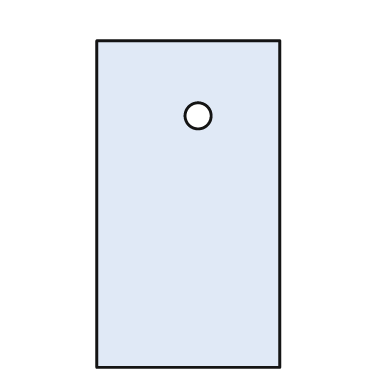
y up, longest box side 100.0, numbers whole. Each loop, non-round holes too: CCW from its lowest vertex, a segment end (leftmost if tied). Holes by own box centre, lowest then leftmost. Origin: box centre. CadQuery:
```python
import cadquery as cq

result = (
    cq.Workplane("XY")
    .moveTo(-28.0, -50.0)
    .lineTo(28.0, -50.0)
    .lineTo(28.0, 50.0)
    .lineTo(-28.0, 50.0)
    .close()
    .moveTo(3.0, 27.0)
    .circle(4.0)
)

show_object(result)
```